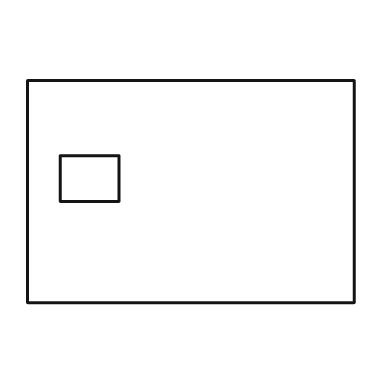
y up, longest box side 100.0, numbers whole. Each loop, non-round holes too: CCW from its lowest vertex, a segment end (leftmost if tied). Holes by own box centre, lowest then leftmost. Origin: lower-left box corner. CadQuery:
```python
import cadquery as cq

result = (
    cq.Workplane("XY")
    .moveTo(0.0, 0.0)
    .lineTo(100.0, 0.0)
    .lineTo(100.0, 68.0)
    .lineTo(0.0, 68.0)
    .close()
    .moveTo(10.0, 31.0)
    .lineTo(28.0, 31.0)
    .lineTo(28.0, 45.0)
    .lineTo(10.0, 45.0)
    .close()
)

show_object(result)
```